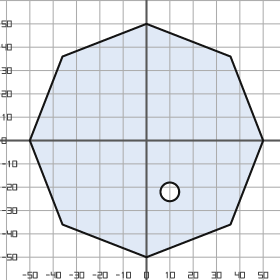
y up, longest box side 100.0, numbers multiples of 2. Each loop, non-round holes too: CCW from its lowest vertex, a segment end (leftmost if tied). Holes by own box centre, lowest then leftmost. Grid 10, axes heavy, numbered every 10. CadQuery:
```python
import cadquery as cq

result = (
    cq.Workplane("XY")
    .moveTo(0.0, -50.0)
    .lineTo(36.0, -36.0)
    .lineTo(50.0, 0.0)
    .lineTo(36.0, 36.0)
    .lineTo(0.0, 50.0)
    .lineTo(-36.0, 36.0)
    .lineTo(-50.0, 0.0)
    .lineTo(-36.0, -36.0)
    .close()
    .moveTo(10.0, -22.0)
    .circle(4.0)
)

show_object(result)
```